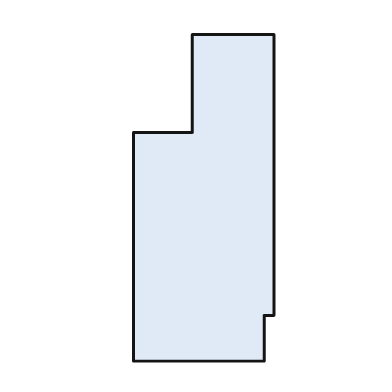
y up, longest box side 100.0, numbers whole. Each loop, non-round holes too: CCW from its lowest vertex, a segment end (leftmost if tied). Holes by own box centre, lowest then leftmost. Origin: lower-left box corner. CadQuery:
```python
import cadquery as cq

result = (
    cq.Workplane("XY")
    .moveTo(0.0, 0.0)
    .lineTo(40.0, 0.0)
    .lineTo(40.0, 14.0)
    .lineTo(43.0, 14.0)
    .lineTo(43.0, 100.0)
    .lineTo(18.0, 100.0)
    .lineTo(18.0, 70.0)
    .lineTo(0.0, 70.0)
    .close()
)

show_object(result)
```